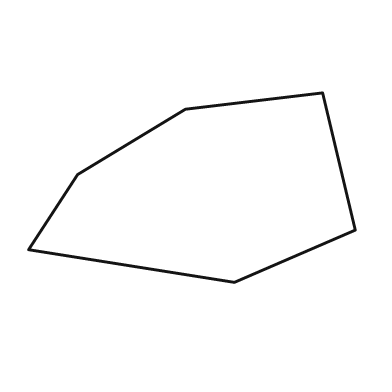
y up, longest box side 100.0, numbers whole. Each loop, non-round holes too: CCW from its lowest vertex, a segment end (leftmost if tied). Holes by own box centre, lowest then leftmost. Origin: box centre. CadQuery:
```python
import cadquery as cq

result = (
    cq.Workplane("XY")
    .moveTo(13.0, -29.0)
    .lineTo(50.0, -13.0)
    .lineTo(40.0, 29.0)
    .lineTo(-2.0, 24.0)
    .lineTo(-35.0, 4.0)
    .lineTo(-50.0, -19.0)
    .close()
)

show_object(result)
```